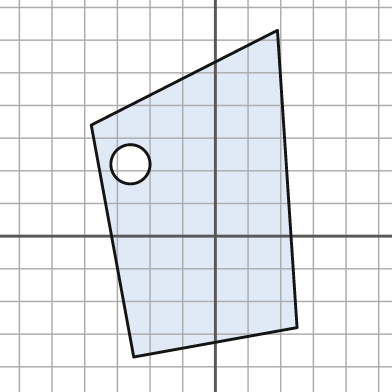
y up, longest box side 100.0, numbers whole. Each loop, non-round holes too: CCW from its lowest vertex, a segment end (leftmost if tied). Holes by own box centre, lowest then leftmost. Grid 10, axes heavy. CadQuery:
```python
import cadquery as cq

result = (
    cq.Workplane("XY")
    .moveTo(-25.0, -37.0)
    .lineTo(25.0, -28.0)
    .lineTo(19.0, 63.0)
    .lineTo(-38.0, 34.0)
    .close()
    .moveTo(-26.0, 22.0)
    .circle(6.0)
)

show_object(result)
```